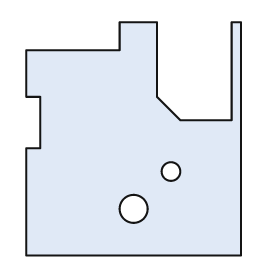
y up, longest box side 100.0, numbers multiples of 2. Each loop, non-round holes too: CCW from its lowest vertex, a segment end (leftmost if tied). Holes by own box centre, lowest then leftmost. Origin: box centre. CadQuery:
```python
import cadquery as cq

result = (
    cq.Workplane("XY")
    .moveTo(-46.0, -50.0)
    .lineTo(46.0, -50.0)
    .lineTo(46.0, 50.0)
    .lineTo(42.0, 50.0)
    .lineTo(42.0, 8.0)
    .lineTo(20.0, 8.0)
    .lineTo(10.0, 18.0)
    .lineTo(10.0, 50.0)
    .lineTo(-6.0, 50.0)
    .lineTo(-6.0, 38.0)
    .lineTo(-46.0, 38.0)
    .lineTo(-46.0, 18.0)
    .lineTo(-40.0, 18.0)
    .lineTo(-40.0, -4.0)
    .lineTo(-46.0, -4.0)
    .close()
    .moveTo(0.0, -30.0)
    .circle(6.0)
    .moveTo(16.0, -14.0)
    .circle(4.0)
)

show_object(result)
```